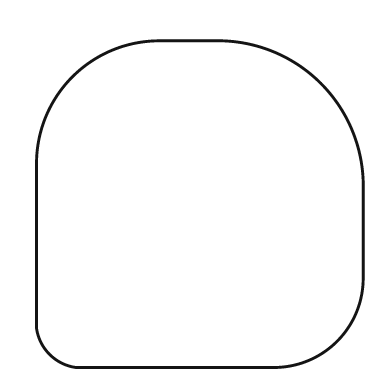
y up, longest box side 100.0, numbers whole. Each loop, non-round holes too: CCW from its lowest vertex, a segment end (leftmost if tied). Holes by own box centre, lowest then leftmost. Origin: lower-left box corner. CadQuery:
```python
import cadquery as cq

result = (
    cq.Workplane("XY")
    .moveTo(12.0, 0.0)
    .lineTo(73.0, 0.0)
    .threePointArc((92.0, 8.0), (100.0, 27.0))
    .lineTo(100.0, 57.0)
    .threePointArc((87.0, 87.0), (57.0, 100.0))
    .lineTo(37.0, 100.0)
    .threePointArc((11.0, 89.0), (0.0, 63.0))
    .lineTo(0.0, 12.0)
    .threePointArc((4.0, 4.0), (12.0, 0.0))
    .close()
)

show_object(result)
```